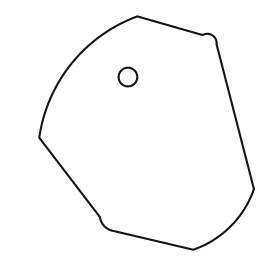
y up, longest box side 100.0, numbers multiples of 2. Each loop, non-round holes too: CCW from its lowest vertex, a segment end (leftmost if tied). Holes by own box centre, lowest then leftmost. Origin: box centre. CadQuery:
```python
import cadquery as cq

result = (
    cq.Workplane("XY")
    .moveTo(20.0, -50.0)
    .threePointArc((36.0, -40.0), (46.0, -24.0))
    .lineTo(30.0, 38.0)
    .threePointArc((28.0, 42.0), (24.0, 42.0))
    .lineTo(-4.0, 50.0)
    .threePointArc((-32.0, 30.0), (-46.0, -2.0))
    .lineTo(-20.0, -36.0)
    .threePointArc((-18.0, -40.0), (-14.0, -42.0))
    .close()
    .moveTo(-8.0, 24.0)
    .circle(4.0)
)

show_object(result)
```